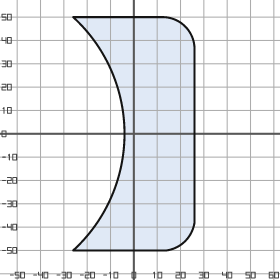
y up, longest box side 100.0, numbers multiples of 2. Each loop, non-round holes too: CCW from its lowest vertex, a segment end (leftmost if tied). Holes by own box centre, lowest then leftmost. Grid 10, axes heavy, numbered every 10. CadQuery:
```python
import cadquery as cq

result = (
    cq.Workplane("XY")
    .moveTo(-26.0, -50.0)
    .lineTo(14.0, -50.0)
    .threePointArc((22.0, -46.0), (26.0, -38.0))
    .lineTo(26.0, 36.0)
    .threePointArc((22.0, 46.0), (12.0, 50.0))
    .lineTo(-26.0, 50.0)
    .threePointArc((-4.0, 0.0), (-26.0, -50.0))
    .close()
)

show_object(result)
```